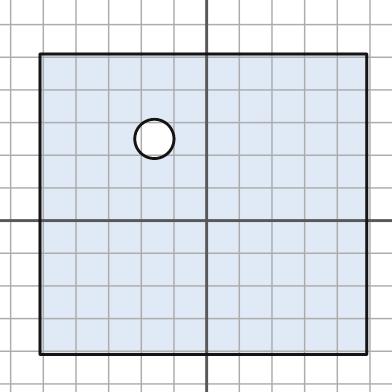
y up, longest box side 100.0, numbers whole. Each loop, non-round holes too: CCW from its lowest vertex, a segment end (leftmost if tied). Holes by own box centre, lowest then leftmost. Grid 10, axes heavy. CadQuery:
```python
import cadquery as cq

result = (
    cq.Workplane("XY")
    .moveTo(-51.0, -41.0)
    .lineTo(49.0, -41.0)
    .lineTo(49.0, 51.0)
    .lineTo(-51.0, 51.0)
    .close()
    .moveTo(-16.0, 25.0)
    .circle(6.0)
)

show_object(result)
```